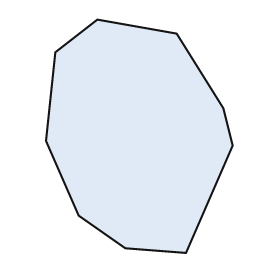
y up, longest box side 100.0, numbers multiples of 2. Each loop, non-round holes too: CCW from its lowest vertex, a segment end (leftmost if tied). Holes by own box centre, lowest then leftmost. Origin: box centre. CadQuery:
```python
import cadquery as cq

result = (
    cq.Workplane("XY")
    .moveTo(20.0, -50.0)
    .lineTo(40.0, -4.0)
    .lineTo(36.0, 12.0)
    .lineTo(16.0, 44.0)
    .lineTo(-18.0, 50.0)
    .lineTo(-36.0, 36.0)
    .lineTo(-40.0, -2.0)
    .lineTo(-26.0, -34.0)
    .lineTo(-6.0, -48.0)
    .close()
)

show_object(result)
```